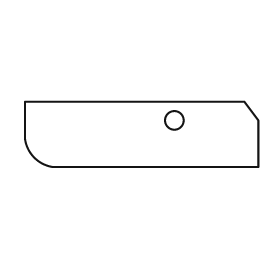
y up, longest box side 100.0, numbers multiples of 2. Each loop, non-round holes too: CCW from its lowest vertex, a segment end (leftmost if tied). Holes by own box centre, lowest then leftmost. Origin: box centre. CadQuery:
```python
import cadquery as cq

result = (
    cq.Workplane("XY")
    .moveTo(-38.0, -14.0)
    .lineTo(50.0, -14.0)
    .lineTo(50.0, 6.0)
    .lineTo(44.0, 14.0)
    .lineTo(-50.0, 14.0)
    .lineTo(-50.0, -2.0)
    .threePointArc((-46.0, -10.0), (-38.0, -14.0))
    .close()
    .moveTo(14.0, 6.0)
    .circle(4.0)
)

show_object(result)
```